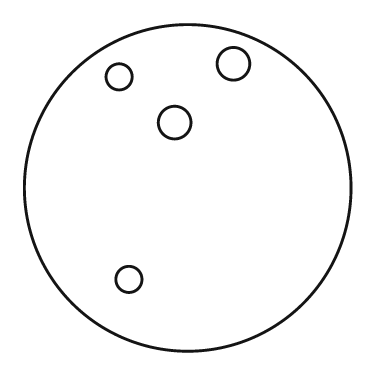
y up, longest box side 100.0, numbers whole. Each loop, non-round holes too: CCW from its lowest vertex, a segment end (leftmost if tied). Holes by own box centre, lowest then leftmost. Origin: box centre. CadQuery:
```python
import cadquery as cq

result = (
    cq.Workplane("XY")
    .moveTo(0.0, 0.0)
    .circle(50.0)
    .moveTo(-18.0, -28.0)
    .circle(4.0)
    .moveTo(-4.0, 20.0)
    .circle(5.0)
    .moveTo(-21.0, 34.0)
    .circle(4.0)
    .moveTo(14.0, 38.0)
    .circle(5.0)
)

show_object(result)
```